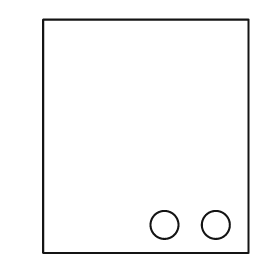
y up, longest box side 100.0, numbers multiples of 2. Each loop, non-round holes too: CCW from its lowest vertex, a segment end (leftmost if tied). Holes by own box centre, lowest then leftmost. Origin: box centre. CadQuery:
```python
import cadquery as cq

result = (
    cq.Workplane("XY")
    .moveTo(-44.0, -50.0)
    .lineTo(44.0, -50.0)
    .lineTo(44.0, 50.0)
    .lineTo(-44.0, 50.0)
    .close()
    .moveTo(8.0, -38.0)
    .circle(6.0)
    .moveTo(30.0, -38.0)
    .circle(6.0)
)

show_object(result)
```